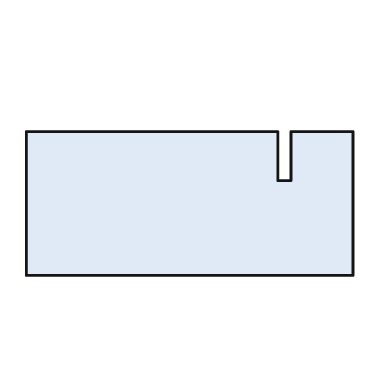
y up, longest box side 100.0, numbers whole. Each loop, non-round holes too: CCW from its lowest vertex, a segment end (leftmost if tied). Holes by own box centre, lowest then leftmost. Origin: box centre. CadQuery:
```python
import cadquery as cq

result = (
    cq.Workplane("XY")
    .moveTo(-50.0, -22.0)
    .lineTo(50.0, -22.0)
    .lineTo(50.0, 22.0)
    .lineTo(31.0, 22.0)
    .lineTo(31.0, 7.0)
    .lineTo(27.0, 7.0)
    .lineTo(27.0, 22.0)
    .lineTo(-50.0, 22.0)
    .close()
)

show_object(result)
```